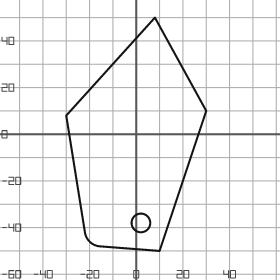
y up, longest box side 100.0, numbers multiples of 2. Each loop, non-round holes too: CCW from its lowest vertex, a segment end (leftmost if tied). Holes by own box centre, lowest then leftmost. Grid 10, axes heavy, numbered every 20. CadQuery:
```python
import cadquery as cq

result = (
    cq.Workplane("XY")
    .moveTo(10.0, -50.0)
    .lineTo(30.0, 10.0)
    .lineTo(8.0, 50.0)
    .lineTo(-30.0, 8.0)
    .lineTo(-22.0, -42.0)
    .threePointArc((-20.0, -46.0), (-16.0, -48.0))
    .close()
    .moveTo(2.0, -38.0)
    .circle(4.0)
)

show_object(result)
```